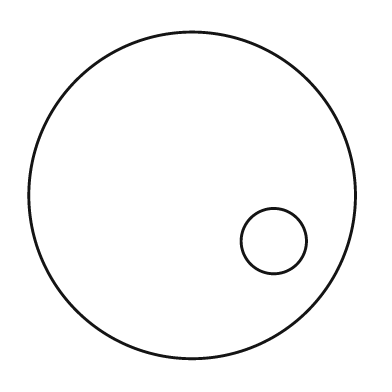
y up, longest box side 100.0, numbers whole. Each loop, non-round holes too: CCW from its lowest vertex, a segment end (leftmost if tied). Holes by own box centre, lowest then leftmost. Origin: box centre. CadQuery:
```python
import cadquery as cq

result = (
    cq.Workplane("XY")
    .moveTo(0.0, 0.0)
    .circle(50.0)
    .moveTo(25.0, -14.0)
    .circle(10.0)
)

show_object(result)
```